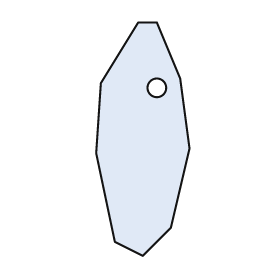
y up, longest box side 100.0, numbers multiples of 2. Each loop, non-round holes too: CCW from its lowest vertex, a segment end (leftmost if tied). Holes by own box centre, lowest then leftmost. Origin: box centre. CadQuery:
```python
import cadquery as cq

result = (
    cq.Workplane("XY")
    .moveTo(0.0, -50.0)
    .lineTo(12.0, -38.0)
    .lineTo(20.0, -4.0)
    .lineTo(16.0, 26.0)
    .lineTo(6.0, 50.0)
    .lineTo(-2.0, 50.0)
    .lineTo(-18.0, 24.0)
    .lineTo(-20.0, -6.0)
    .lineTo(-12.0, -44.0)
    .close()
    .moveTo(6.0, 22.0)
    .circle(4.0)
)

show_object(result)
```